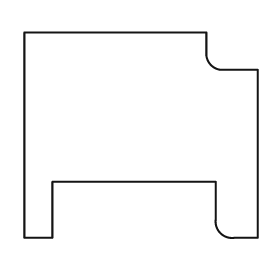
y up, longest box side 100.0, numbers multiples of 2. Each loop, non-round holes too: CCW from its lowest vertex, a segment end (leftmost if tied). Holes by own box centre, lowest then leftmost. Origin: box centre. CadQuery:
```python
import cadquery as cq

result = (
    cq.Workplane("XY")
    .moveTo(-50.0, -44.0)
    .lineTo(-38.0, -44.0)
    .lineTo(-38.0, -20.0)
    .lineTo(32.0, -20.0)
    .lineTo(32.0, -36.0)
    .threePointArc((34.0, -42.0), (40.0, -44.0))
    .lineTo(50.0, -44.0)
    .lineTo(50.0, 28.0)
    .lineTo(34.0, 28.0)
    .threePointArc((30.0, 30.0), (28.0, 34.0))
    .lineTo(28.0, 44.0)
    .lineTo(-50.0, 44.0)
    .close()
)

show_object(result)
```